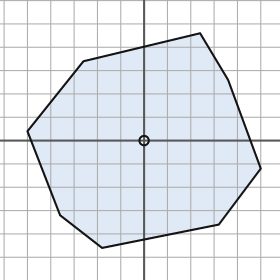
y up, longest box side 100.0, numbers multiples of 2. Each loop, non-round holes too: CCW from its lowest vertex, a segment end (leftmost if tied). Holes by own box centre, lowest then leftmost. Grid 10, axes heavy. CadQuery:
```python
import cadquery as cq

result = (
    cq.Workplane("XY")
    .moveTo(-18.0, -46.0)
    .lineTo(32.0, -36.0)
    .lineTo(50.0, -12.0)
    .lineTo(36.0, 26.0)
    .lineTo(24.0, 46.0)
    .lineTo(-26.0, 34.0)
    .lineTo(-50.0, 4.0)
    .lineTo(-36.0, -32.0)
    .close()
    .moveTo(0.0, 0.0)
    .circle(2.0)
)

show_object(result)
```